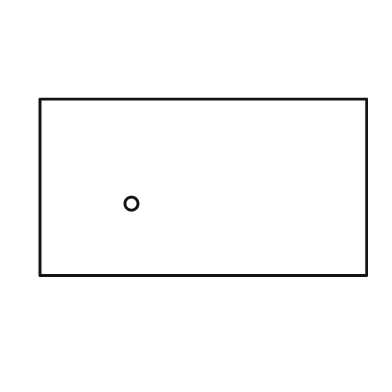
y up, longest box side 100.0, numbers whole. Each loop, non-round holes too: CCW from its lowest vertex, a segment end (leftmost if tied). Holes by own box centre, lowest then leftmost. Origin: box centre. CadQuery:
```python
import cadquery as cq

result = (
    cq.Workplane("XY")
    .moveTo(-50.0, -27.0)
    .lineTo(50.0, -27.0)
    .lineTo(50.0, 27.0)
    .lineTo(-50.0, 27.0)
    .close()
    .moveTo(-22.0, -5.0)
    .circle(2.0)
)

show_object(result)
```